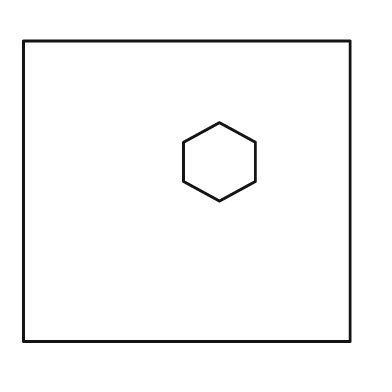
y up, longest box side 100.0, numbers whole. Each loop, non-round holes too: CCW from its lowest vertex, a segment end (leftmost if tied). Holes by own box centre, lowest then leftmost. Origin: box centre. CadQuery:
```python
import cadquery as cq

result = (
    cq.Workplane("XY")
    .moveTo(-50.0, -46.0)
    .lineTo(50.0, -46.0)
    .lineTo(50.0, 46.0)
    .lineTo(-50.0, 46.0)
    .close()
    .moveTo(10.0, -3.0)
    .lineTo(21.0, 3.0)
    .lineTo(21.0, 15.0)
    .lineTo(10.0, 21.0)
    .lineTo(-1.0, 15.0)
    .lineTo(-1.0, 3.0)
    .close()
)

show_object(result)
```